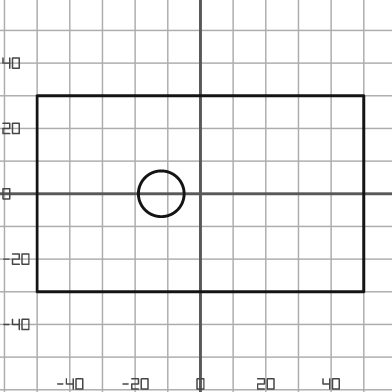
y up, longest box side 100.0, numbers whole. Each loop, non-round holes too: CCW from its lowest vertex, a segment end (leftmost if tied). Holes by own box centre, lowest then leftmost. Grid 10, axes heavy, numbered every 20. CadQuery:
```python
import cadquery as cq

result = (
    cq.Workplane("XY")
    .moveTo(-50.0, -30.0)
    .lineTo(50.0, -30.0)
    .lineTo(50.0, 30.0)
    .lineTo(-50.0, 30.0)
    .close()
    .moveTo(-12.0, 0.0)
    .circle(7.0)
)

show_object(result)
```